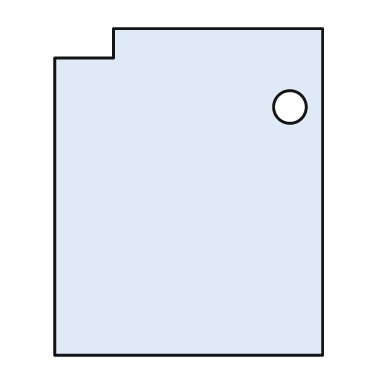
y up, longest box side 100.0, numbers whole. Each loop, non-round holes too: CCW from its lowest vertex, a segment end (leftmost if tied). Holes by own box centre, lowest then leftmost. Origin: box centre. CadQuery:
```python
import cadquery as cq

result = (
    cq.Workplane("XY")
    .moveTo(-41.0, -50.0)
    .lineTo(41.0, -50.0)
    .lineTo(41.0, 50.0)
    .lineTo(-23.0, 50.0)
    .lineTo(-23.0, 41.0)
    .lineTo(-41.0, 41.0)
    .close()
    .moveTo(31.0, 26.0)
    .circle(5.0)
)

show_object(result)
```